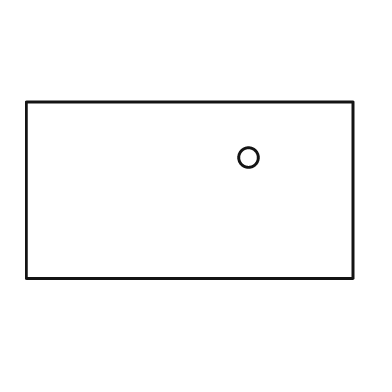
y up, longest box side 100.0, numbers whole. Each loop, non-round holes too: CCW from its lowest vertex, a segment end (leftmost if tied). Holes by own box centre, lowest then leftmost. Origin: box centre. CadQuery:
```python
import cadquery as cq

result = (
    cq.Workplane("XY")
    .moveTo(-50.0, -27.0)
    .lineTo(50.0, -27.0)
    .lineTo(50.0, 27.0)
    .lineTo(-50.0, 27.0)
    .close()
    .moveTo(18.0, 10.0)
    .circle(3.0)
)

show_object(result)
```